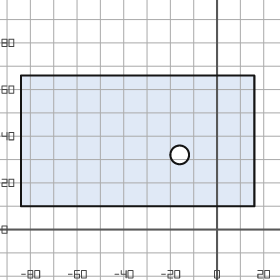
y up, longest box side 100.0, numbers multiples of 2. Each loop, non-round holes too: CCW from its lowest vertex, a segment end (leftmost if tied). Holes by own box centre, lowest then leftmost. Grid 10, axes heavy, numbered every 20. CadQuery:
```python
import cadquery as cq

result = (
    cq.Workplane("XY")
    .moveTo(-84.0, 10.0)
    .lineTo(16.0, 10.0)
    .lineTo(16.0, 66.0)
    .lineTo(-84.0, 66.0)
    .close()
    .moveTo(-16.0, 32.0)
    .circle(4.0)
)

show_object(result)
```